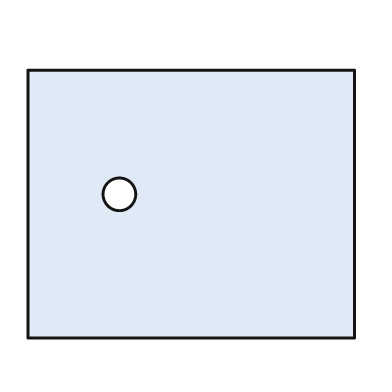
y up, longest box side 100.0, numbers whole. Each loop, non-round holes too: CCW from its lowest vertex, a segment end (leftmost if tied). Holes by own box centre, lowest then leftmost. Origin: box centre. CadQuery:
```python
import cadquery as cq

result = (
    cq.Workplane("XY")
    .moveTo(-50.0, -41.0)
    .lineTo(50.0, -41.0)
    .lineTo(50.0, 41.0)
    .lineTo(-50.0, 41.0)
    .close()
    .moveTo(-22.0, 3.0)
    .circle(5.0)
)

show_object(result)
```